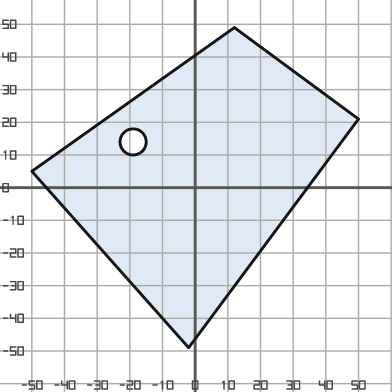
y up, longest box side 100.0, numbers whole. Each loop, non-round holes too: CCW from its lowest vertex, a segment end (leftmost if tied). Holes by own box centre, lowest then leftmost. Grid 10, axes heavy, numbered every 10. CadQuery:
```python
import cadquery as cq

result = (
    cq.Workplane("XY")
    .moveTo(-2.0, -49.0)
    .lineTo(50.0, 21.0)
    .lineTo(12.0, 49.0)
    .lineTo(-50.0, 5.0)
    .close()
    .moveTo(-19.0, 14.0)
    .circle(4.0)
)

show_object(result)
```